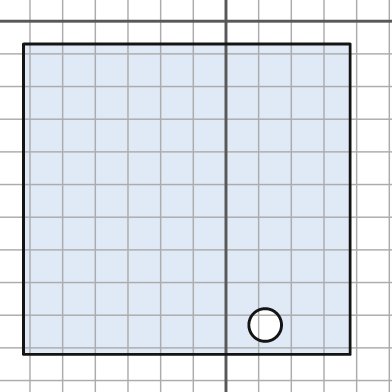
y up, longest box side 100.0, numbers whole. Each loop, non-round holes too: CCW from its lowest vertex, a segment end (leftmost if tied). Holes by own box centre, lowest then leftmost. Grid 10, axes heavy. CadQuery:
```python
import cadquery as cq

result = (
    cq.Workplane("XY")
    .moveTo(-62.0, -102.0)
    .lineTo(38.0, -102.0)
    .lineTo(38.0, -7.0)
    .lineTo(-62.0, -7.0)
    .close()
    .moveTo(12.0, -93.0)
    .circle(5.0)
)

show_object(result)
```